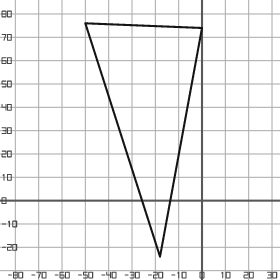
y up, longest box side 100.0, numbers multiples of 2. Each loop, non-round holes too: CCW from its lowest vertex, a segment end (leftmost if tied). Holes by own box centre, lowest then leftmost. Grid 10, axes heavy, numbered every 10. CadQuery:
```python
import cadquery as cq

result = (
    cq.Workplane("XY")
    .moveTo(-18.0, -24.0)
    .lineTo(0.0, 74.0)
    .lineTo(-50.0, 76.0)
    .close()
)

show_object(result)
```